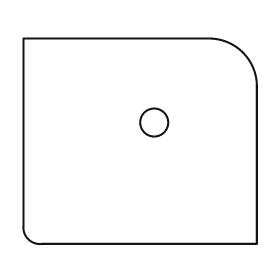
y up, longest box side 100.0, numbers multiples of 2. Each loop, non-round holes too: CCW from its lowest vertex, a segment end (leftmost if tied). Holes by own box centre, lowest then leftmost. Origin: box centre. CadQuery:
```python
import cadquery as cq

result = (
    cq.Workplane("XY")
    .moveTo(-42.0, -44.0)
    .lineTo(50.0, -44.0)
    .lineTo(50.0, 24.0)
    .threePointArc((44.0, 38.0), (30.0, 44.0))
    .lineTo(-50.0, 44.0)
    .lineTo(-50.0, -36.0)
    .threePointArc((-48.0, -42.0), (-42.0, -44.0))
    .close()
    .moveTo(6.0, 8.0)
    .circle(6.0)
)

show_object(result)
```